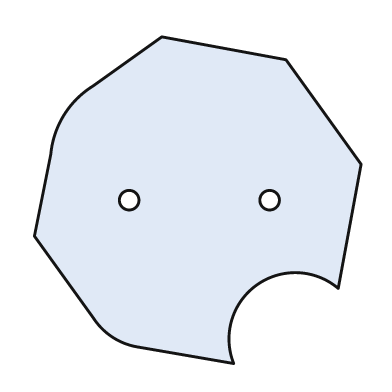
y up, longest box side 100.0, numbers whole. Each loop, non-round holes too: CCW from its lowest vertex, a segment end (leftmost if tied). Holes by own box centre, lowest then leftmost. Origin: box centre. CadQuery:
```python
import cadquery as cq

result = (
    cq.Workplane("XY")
    .moveTo(11.0, -50.0)
    .threePointArc((18.0, -26.0), (43.0, -27.0))
    .lineTo(50.0, 11.0)
    .lineTo(27.0, 43.0)
    .lineTo(-11.0, 50.0)
    .lineTo(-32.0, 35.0)
    .threePointArc((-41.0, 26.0), (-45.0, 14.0))
    .lineTo(-50.0, -11.0)
    .lineTo(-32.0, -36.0)
    .threePointArc((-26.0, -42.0), (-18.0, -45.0))
    .close()
    .moveTo(-21.0, 0.0)
    .circle(3.0)
    .moveTo(22.0, 0.0)
    .circle(3.0)
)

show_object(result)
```